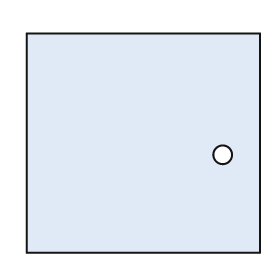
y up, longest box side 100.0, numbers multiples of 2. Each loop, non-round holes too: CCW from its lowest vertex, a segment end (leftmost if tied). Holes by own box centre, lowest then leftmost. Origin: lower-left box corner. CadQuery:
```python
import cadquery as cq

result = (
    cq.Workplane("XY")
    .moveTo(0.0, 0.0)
    .lineTo(100.0, 0.0)
    .lineTo(100.0, 94.0)
    .lineTo(0.0, 94.0)
    .close()
    .moveTo(84.0, 42.0)
    .circle(4.0)
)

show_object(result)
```